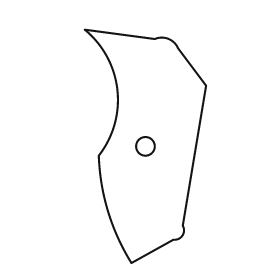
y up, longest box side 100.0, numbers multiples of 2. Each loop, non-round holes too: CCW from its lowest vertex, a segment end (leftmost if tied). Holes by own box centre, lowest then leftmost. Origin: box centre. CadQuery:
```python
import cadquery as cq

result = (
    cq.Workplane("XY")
    .moveTo(-6.0, -50.0)
    .lineTo(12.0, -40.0)
    .threePointArc((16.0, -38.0), (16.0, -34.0))
    .lineTo(26.0, 26.0)
    .lineTo(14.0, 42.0)
    .threePointArc((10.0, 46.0), (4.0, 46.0))
    .lineTo(-26.0, 50.0)
    .threePointArc((-12.0, 24.0), (-20.0, -4.0))
    .threePointArc((-16.0, -28.0), (-6.0, -50.0))
    .close()
    .moveTo(0.0, 0.0)
    .circle(4.0)
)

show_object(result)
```